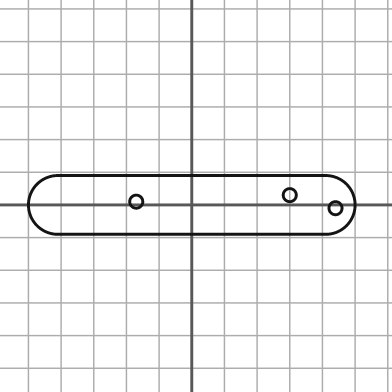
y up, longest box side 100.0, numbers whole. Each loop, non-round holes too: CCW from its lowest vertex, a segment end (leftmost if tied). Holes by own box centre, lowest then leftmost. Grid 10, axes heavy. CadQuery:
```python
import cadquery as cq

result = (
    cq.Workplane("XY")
    .moveTo(-41.0, -9.0)
    .lineTo(41.0, -9.0)
    .threePointArc((50.0, 0.0), (41.0, 9.0))
    .lineTo(-41.0, 9.0)
    .threePointArc((-50.0, 0.0), (-41.0, -9.0))
    .close()
    .moveTo(44.0, -1.0)
    .circle(2.0)
    .moveTo(-17.0, 1.0)
    .circle(2.0)
    .moveTo(30.0, 3.0)
    .circle(2.0)
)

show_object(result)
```